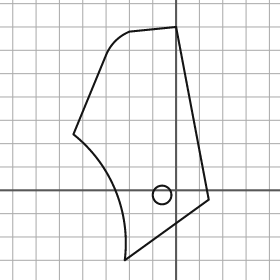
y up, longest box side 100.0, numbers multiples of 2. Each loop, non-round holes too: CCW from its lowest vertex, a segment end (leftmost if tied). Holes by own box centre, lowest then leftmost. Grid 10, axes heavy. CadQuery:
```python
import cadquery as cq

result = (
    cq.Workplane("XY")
    .moveTo(-22.0, -30.0)
    .lineTo(14.0, -4.0)
    .lineTo(0.0, 70.0)
    .lineTo(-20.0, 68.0)
    .threePointArc((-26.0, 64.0), (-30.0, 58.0))
    .lineTo(-44.0, 24.0)
    .threePointArc((-26.0, 0.0), (-22.0, -30.0))
    .close()
    .moveTo(-6.0, -2.0)
    .circle(4.0)
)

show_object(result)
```